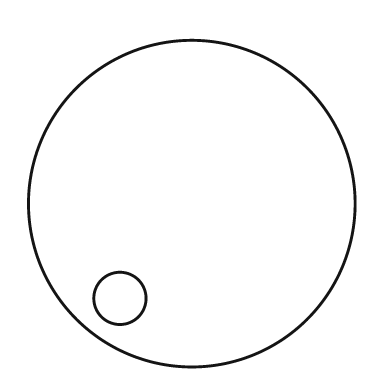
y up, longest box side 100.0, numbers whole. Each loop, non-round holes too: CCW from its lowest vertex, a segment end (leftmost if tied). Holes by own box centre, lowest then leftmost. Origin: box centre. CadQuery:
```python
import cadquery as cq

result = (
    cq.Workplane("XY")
    .moveTo(0.0, 0.0)
    .circle(50.0)
    .moveTo(-22.0, -29.0)
    .circle(8.0)
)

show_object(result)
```